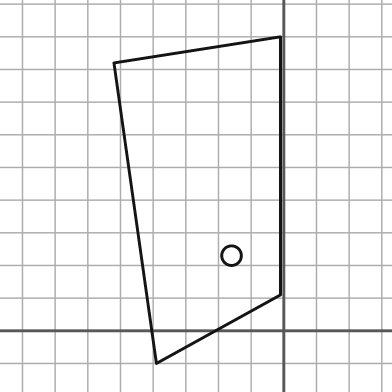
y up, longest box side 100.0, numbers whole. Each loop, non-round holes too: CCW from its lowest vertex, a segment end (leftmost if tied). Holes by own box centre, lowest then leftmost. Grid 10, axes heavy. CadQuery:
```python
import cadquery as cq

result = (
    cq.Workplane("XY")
    .moveTo(-39.0, -10.0)
    .lineTo(-1.0, 11.0)
    .lineTo(-1.0, 90.0)
    .lineTo(-52.0, 82.0)
    .close()
    .moveTo(-16.0, 23.0)
    .circle(3.0)
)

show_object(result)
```